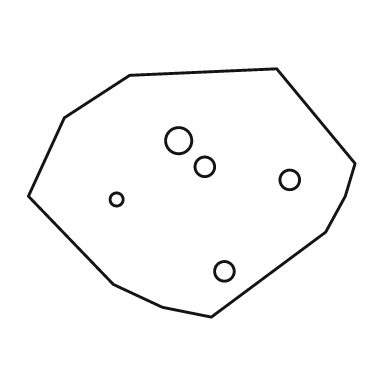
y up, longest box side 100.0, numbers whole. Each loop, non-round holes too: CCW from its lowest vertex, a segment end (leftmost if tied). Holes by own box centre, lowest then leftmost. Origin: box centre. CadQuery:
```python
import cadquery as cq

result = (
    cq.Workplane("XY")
    .moveTo(6.0, -38.0)
    .lineTo(41.0, -12.0)
    .lineTo(47.0, -1.0)
    .lineTo(50.0, 9.0)
    .lineTo(26.0, 38.0)
    .lineTo(-19.0, 36.0)
    .lineTo(-39.0, 23.0)
    .lineTo(-50.0, -1.0)
    .lineTo(-24.0, -28.0)
    .lineTo(-9.0, -35.0)
    .close()
    .moveTo(10.0, -24.0)
    .circle(3.0)
    .moveTo(-23.0, -2.0)
    .circle(2.0)
    .moveTo(30.0, 4.0)
    .circle(3.0)
    .moveTo(4.0, 8.0)
    .circle(3.0)
    .moveTo(-4.0, 16.0)
    .circle(4.0)
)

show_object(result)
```